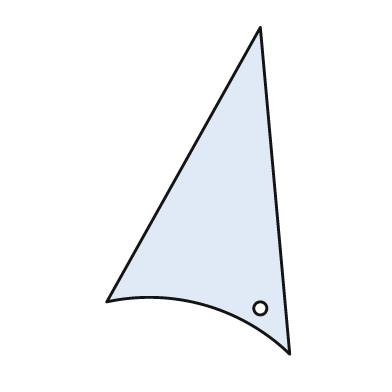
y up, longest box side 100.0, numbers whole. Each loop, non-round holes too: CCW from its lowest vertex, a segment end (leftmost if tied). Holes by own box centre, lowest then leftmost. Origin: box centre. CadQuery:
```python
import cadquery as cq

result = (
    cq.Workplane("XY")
    .moveTo(28.0, -50.0)
    .lineTo(19.0, 50.0)
    .lineTo(-28.0, -34.0)
    .threePointArc((2.0, -35.0), (28.0, -50.0))
    .close()
    .moveTo(19.0, -36.0)
    .circle(2.0)
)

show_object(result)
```